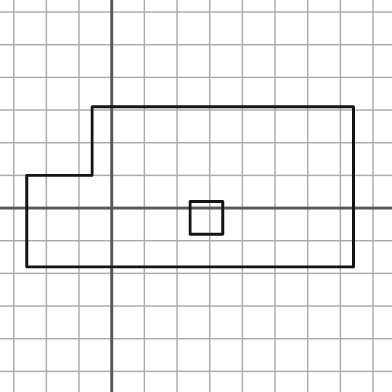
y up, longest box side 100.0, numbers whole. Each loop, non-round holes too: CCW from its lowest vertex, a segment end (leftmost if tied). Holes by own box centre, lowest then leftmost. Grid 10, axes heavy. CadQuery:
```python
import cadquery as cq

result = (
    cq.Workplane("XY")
    .moveTo(-26.0, -18.0)
    .lineTo(74.0, -18.0)
    .lineTo(74.0, 31.0)
    .lineTo(-6.0, 31.0)
    .lineTo(-6.0, 10.0)
    .lineTo(-26.0, 10.0)
    .close()
    .moveTo(24.0, -8.0)
    .lineTo(34.0, -8.0)
    .lineTo(34.0, 2.0)
    .lineTo(24.0, 2.0)
    .close()
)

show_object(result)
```